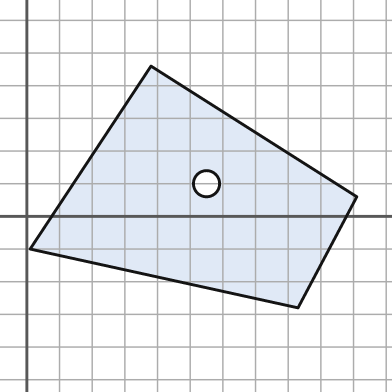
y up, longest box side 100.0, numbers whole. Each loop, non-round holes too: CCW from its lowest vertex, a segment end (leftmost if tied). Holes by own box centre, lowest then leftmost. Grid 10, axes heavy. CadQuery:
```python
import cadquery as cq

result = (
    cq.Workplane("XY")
    .moveTo(83.0, -28.0)
    .lineTo(101.0, 6.0)
    .lineTo(38.0, 46.0)
    .lineTo(1.0, -10.0)
    .close()
    .moveTo(55.0, 10.0)
    .circle(4.0)
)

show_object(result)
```